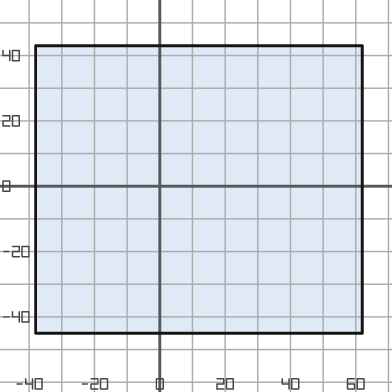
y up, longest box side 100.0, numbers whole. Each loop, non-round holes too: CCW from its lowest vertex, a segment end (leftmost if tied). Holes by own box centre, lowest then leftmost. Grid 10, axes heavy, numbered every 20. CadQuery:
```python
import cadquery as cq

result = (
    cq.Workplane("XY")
    .moveTo(-38.0, -45.0)
    .lineTo(62.0, -45.0)
    .lineTo(62.0, 43.0)
    .lineTo(-38.0, 43.0)
    .close()
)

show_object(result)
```